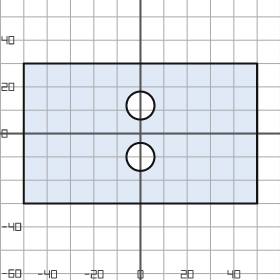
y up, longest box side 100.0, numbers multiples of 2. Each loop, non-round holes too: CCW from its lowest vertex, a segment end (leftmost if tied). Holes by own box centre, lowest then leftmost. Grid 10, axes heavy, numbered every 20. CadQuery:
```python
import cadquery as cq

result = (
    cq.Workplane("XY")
    .moveTo(-50.0, -30.0)
    .lineTo(50.0, -30.0)
    .lineTo(50.0, 30.0)
    .lineTo(-50.0, 30.0)
    .close()
    .moveTo(0.0, -10.0)
    .circle(6.0)
    .moveTo(0.0, 12.0)
    .circle(6.0)
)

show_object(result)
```